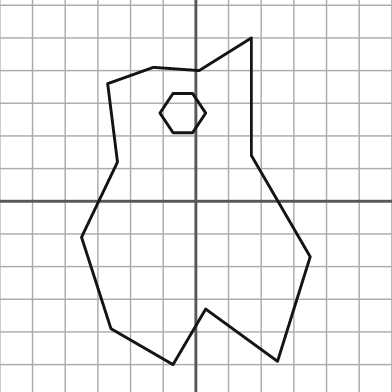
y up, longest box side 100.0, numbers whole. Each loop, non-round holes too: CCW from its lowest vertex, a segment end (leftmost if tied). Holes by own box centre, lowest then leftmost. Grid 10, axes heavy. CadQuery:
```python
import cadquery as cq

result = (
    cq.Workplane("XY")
    .moveTo(-7.0, -50.0)
    .lineTo(3.0, -33.0)
    .lineTo(25.0, -49.0)
    .lineTo(35.0, -17.0)
    .lineTo(17.0, 14.0)
    .lineTo(17.0, 50.0)
    .lineTo(1.0, 40.0)
    .lineTo(-13.0, 41.0)
    .lineTo(-27.0, 36.0)
    .lineTo(-24.0, 12.0)
    .lineTo(-35.0, -11.0)
    .lineTo(-26.0, -39.0)
    .close()
    .moveTo(-7.0, 21.0)
    .lineTo(-1.0, 21.0)
    .lineTo(3.0, 27.0)
    .lineTo(-1.0, 33.0)
    .lineTo(-7.0, 33.0)
    .lineTo(-11.0, 27.0)
    .close()
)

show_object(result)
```